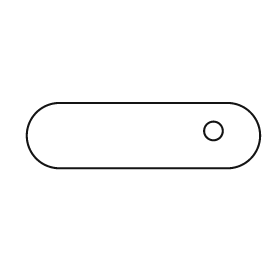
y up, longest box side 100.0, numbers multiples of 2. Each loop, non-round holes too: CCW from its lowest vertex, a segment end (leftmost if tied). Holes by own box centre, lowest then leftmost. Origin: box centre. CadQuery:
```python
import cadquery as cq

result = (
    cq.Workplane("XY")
    .moveTo(-36.0, -14.0)
    .lineTo(36.0, -14.0)
    .threePointArc((50.0, 0.0), (36.0, 14.0))
    .lineTo(-36.0, 14.0)
    .threePointArc((-50.0, 0.0), (-36.0, -14.0))
    .close()
    .moveTo(30.0, 2.0)
    .circle(4.0)
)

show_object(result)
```